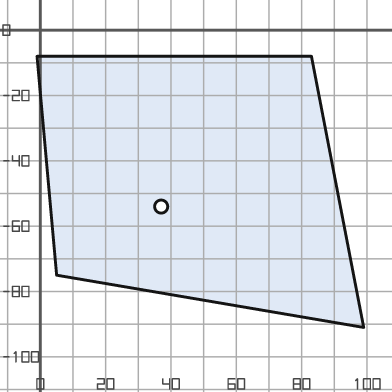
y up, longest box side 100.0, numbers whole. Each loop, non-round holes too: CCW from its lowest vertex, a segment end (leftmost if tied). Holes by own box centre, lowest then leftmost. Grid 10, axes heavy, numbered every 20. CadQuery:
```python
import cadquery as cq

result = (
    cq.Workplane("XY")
    .moveTo(99.0, -91.0)
    .lineTo(83.0, -8.0)
    .lineTo(-1.0, -8.0)
    .lineTo(5.0, -75.0)
    .close()
    .moveTo(37.0, -54.0)
    .circle(2.0)
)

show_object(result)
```